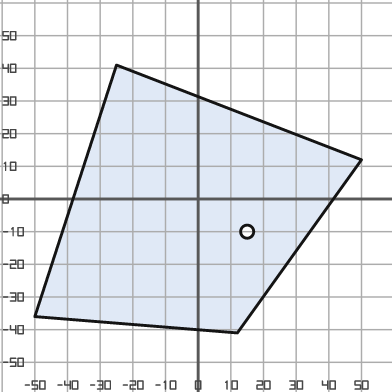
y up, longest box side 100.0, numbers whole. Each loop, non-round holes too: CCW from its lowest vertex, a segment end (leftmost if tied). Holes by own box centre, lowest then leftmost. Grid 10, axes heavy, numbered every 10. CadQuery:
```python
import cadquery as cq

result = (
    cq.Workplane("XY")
    .moveTo(12.0, -41.0)
    .lineTo(50.0, 12.0)
    .lineTo(-25.0, 41.0)
    .lineTo(-50.0, -36.0)
    .close()
    .moveTo(15.0, -10.0)
    .circle(2.0)
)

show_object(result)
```